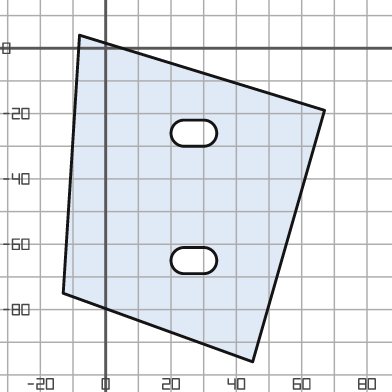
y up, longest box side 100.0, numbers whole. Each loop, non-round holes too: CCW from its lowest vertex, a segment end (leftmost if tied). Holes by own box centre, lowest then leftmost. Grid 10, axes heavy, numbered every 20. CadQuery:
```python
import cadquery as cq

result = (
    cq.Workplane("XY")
    .moveTo(45.0, -96.0)
    .lineTo(67.0, -19.0)
    .lineTo(-8.0, 4.0)
    .lineTo(-13.0, -75.0)
    .close()
    .moveTo(24.0, -69.0)
    .lineTo(30.0, -69.0)
    .threePointArc((34.0, -65.0), (30.0, -61.0))
    .lineTo(24.0, -61.0)
    .threePointArc((20.0, -65.0), (24.0, -69.0))
    .close()
    .moveTo(24.0, -30.0)
    .lineTo(30.0, -30.0)
    .threePointArc((34.0, -26.0), (30.0, -22.0))
    .lineTo(24.0, -22.0)
    .threePointArc((20.0, -26.0), (24.0, -30.0))
    .close()
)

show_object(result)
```